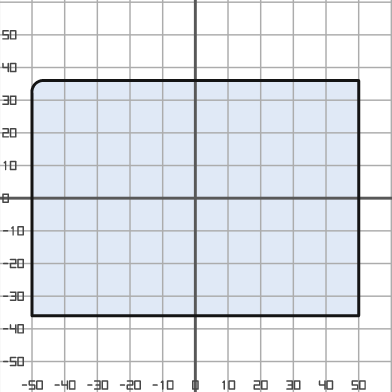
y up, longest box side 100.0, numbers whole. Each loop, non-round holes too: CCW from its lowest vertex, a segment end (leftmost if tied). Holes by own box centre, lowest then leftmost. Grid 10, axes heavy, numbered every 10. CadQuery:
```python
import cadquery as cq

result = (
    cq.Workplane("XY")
    .moveTo(-50.0, -36.0)
    .lineTo(50.0, -36.0)
    .lineTo(50.0, 36.0)
    .lineTo(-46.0, 36.0)
    .threePointArc((-49.0, 35.0), (-50.0, 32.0))
    .close()
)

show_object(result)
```